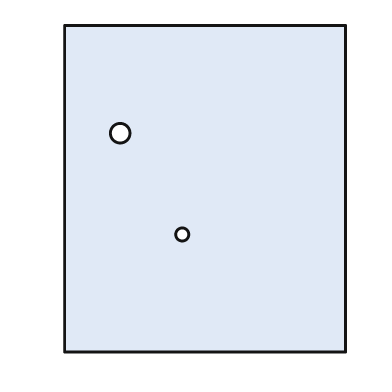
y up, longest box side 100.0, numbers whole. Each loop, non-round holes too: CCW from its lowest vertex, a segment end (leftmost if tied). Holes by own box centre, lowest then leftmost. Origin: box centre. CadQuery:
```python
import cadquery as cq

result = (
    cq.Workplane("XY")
    .moveTo(-43.0, -50.0)
    .lineTo(43.0, -50.0)
    .lineTo(43.0, 50.0)
    .lineTo(-43.0, 50.0)
    .close()
    .moveTo(-7.0, -14.0)
    .circle(2.0)
    .moveTo(-26.0, 17.0)
    .circle(3.0)
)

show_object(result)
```